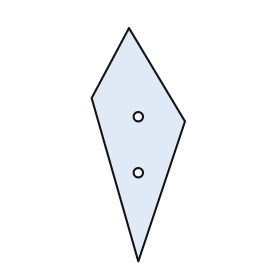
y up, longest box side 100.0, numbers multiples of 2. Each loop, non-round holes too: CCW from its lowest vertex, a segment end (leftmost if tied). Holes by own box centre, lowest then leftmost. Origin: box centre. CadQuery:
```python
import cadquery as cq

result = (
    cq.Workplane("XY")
    .moveTo(0.0, -50.0)
    .lineTo(20.0, 10.0)
    .lineTo(-4.0, 50.0)
    .lineTo(-20.0, 20.0)
    .close()
    .moveTo(0.0, -12.0)
    .circle(2.0)
    .moveTo(0.0, 12.0)
    .circle(2.0)
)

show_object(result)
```